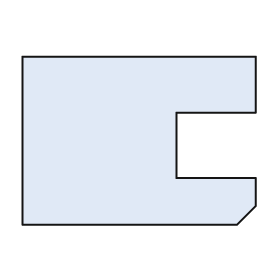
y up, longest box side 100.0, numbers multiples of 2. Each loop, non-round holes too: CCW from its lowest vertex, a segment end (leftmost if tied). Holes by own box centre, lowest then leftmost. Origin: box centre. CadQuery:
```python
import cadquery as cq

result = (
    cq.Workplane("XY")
    .moveTo(-50.0, -36.0)
    .lineTo(42.0, -36.0)
    .lineTo(50.0, -28.0)
    .lineTo(50.0, -16.0)
    .lineTo(16.0, -16.0)
    .lineTo(16.0, 12.0)
    .lineTo(50.0, 12.0)
    .lineTo(50.0, 36.0)
    .lineTo(-50.0, 36.0)
    .close()
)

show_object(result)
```